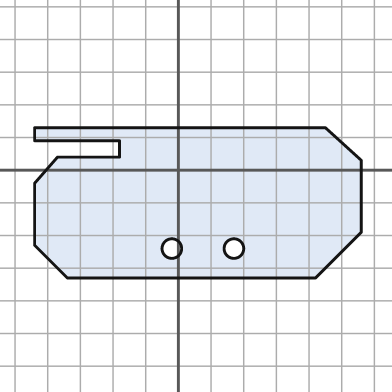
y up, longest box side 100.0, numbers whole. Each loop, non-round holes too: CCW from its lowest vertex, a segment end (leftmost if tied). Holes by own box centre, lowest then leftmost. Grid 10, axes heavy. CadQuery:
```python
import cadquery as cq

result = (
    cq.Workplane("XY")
    .moveTo(-34.0, -33.0)
    .lineTo(42.0, -33.0)
    .lineTo(56.0, -19.0)
    .lineTo(56.0, 3.0)
    .lineTo(45.0, 13.0)
    .lineTo(-44.0, 13.0)
    .lineTo(-44.0, 9.0)
    .lineTo(-18.0, 9.0)
    .lineTo(-18.0, 4.0)
    .lineTo(-37.0, 4.0)
    .lineTo(-44.0, -4.0)
    .lineTo(-44.0, -23.0)
    .close()
    .moveTo(-2.0, -24.0)
    .circle(3.0)
    .moveTo(17.0, -24.0)
    .circle(3.0)
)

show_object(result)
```